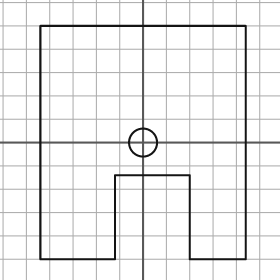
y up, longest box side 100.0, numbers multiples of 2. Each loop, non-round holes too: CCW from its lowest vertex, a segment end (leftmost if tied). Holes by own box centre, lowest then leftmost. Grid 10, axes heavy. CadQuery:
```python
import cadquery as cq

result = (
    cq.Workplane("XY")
    .moveTo(-44.0, -50.0)
    .lineTo(-12.0, -50.0)
    .lineTo(-12.0, -14.0)
    .lineTo(20.0, -14.0)
    .lineTo(20.0, -50.0)
    .lineTo(44.0, -50.0)
    .lineTo(44.0, 50.0)
    .lineTo(-44.0, 50.0)
    .close()
    .moveTo(0.0, 0.0)
    .circle(6.0)
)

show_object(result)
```